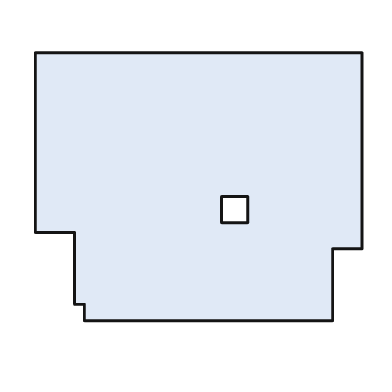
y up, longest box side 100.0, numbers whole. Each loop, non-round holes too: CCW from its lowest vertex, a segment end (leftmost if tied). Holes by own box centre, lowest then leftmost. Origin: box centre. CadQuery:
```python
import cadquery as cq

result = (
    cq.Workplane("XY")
    .moveTo(-35.0, -41.0)
    .lineTo(41.0, -41.0)
    .lineTo(41.0, -19.0)
    .lineTo(50.0, -19.0)
    .lineTo(50.0, 41.0)
    .lineTo(-50.0, 41.0)
    .lineTo(-50.0, -14.0)
    .lineTo(-38.0, -14.0)
    .lineTo(-38.0, -36.0)
    .lineTo(-35.0, -36.0)
    .close()
    .moveTo(7.0, -11.0)
    .lineTo(15.0, -11.0)
    .lineTo(15.0, -3.0)
    .lineTo(7.0, -3.0)
    .close()
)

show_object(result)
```